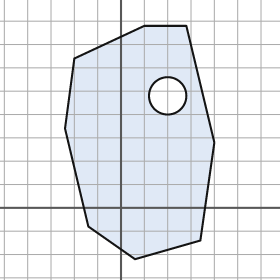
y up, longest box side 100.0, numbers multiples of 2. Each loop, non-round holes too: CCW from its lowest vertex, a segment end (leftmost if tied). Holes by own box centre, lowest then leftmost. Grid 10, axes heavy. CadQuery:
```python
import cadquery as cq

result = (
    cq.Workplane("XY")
    .moveTo(6.0, -22.0)
    .lineTo(34.0, -14.0)
    .lineTo(40.0, 28.0)
    .lineTo(28.0, 78.0)
    .lineTo(10.0, 78.0)
    .lineTo(-20.0, 64.0)
    .lineTo(-24.0, 34.0)
    .lineTo(-14.0, -8.0)
    .close()
    .moveTo(20.0, 48.0)
    .circle(8.0)
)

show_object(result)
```